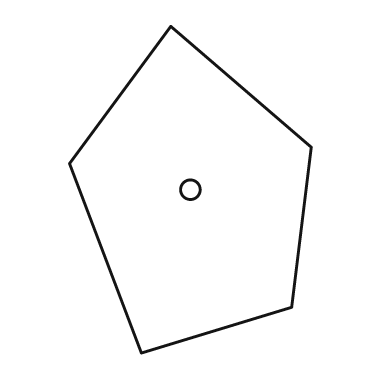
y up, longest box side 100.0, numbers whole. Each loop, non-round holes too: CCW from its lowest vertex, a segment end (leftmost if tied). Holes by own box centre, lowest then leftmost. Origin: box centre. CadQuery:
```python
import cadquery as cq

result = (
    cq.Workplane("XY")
    .moveTo(-15.0, -50.0)
    .lineTo(31.0, -36.0)
    .lineTo(37.0, 13.0)
    .lineTo(-6.0, 50.0)
    .lineTo(-37.0, 8.0)
    .close()
    .moveTo(0.0, 0.0)
    .circle(3.0)
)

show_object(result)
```